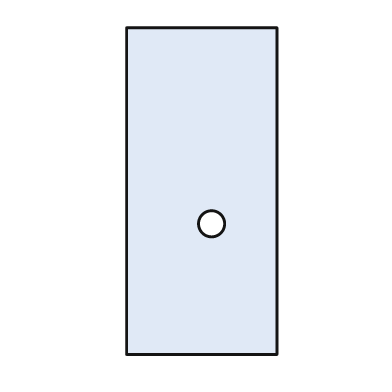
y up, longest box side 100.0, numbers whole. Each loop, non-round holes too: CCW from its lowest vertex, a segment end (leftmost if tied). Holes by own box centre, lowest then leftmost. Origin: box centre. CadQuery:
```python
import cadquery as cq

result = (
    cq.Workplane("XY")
    .moveTo(-23.0, -50.0)
    .lineTo(23.0, -50.0)
    .lineTo(23.0, 50.0)
    .lineTo(-23.0, 50.0)
    .close()
    .moveTo(3.0, -10.0)
    .circle(4.0)
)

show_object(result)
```